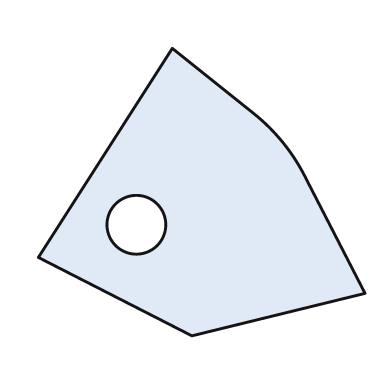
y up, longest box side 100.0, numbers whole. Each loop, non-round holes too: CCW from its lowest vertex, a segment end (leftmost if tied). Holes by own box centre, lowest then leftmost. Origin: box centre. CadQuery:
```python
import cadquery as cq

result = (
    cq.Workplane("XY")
    .moveTo(-3.0, -44.0)
    .lineTo(50.0, -31.0)
    .lineTo(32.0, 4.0)
    .threePointArc((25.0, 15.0), (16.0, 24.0))
    .lineTo(-9.0, 44.0)
    .lineTo(-50.0, -20.0)
    .close()
    .moveTo(-20.0, -10.0)
    .circle(9.0)
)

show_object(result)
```